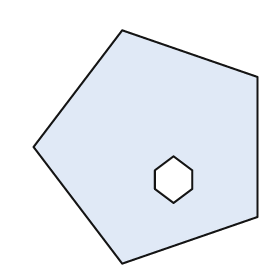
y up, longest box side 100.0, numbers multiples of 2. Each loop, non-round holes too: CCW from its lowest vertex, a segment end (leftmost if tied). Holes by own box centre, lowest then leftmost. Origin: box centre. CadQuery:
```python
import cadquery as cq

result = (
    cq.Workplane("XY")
    .moveTo(-10.0, -50.0)
    .lineTo(48.0, -30.0)
    .lineTo(48.0, 30.0)
    .lineTo(-10.0, 50.0)
    .lineTo(-48.0, 0.0)
    .close()
    .moveTo(12.0, -24.0)
    .lineTo(20.0, -18.0)
    .lineTo(20.0, -10.0)
    .lineTo(12.0, -4.0)
    .lineTo(4.0, -10.0)
    .lineTo(4.0, -18.0)
    .close()
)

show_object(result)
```